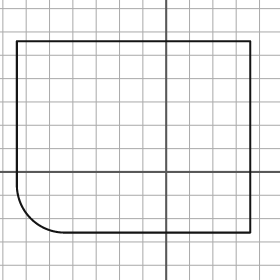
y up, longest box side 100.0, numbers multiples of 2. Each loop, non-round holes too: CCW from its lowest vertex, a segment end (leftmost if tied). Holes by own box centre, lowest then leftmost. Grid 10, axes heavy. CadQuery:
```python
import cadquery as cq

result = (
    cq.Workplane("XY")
    .moveTo(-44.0, -26.0)
    .lineTo(36.0, -26.0)
    .lineTo(36.0, 56.0)
    .lineTo(-64.0, 56.0)
    .lineTo(-64.0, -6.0)
    .threePointArc((-58.0, -20.0), (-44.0, -26.0))
    .close()
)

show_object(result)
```